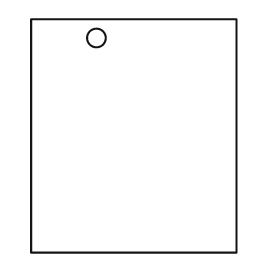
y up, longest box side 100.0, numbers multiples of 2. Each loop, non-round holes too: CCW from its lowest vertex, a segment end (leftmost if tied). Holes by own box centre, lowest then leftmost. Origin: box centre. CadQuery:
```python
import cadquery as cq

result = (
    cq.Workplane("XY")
    .moveTo(-44.0, -50.0)
    .lineTo(44.0, -50.0)
    .lineTo(44.0, 50.0)
    .lineTo(-44.0, 50.0)
    .close()
    .moveTo(-16.0, 42.0)
    .circle(4.0)
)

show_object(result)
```